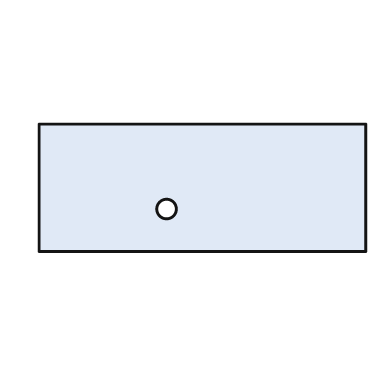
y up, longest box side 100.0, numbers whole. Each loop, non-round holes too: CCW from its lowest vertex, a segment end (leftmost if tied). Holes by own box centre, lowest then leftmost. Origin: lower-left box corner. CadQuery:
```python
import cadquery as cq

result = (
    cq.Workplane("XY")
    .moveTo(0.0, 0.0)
    .lineTo(100.0, 0.0)
    .lineTo(100.0, 39.0)
    .lineTo(0.0, 39.0)
    .close()
    .moveTo(39.0, 13.0)
    .circle(3.0)
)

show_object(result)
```